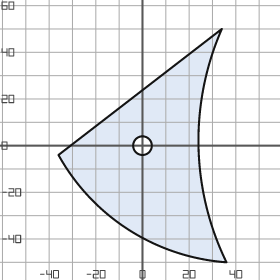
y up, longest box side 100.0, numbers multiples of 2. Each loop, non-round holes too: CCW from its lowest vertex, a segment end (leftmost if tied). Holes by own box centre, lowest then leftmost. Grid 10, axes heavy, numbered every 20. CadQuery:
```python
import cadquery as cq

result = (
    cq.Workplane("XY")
    .moveTo(36.0, -50.0)
    .threePointArc((24.0, 0.0), (34.0, 50.0))
    .lineTo(-36.0, -4.0)
    .threePointArc((-6.0, -36.0), (36.0, -50.0))
    .close()
    .moveTo(0.0, 0.0)
    .circle(4.0)
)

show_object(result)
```